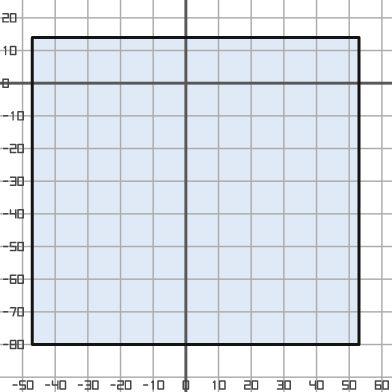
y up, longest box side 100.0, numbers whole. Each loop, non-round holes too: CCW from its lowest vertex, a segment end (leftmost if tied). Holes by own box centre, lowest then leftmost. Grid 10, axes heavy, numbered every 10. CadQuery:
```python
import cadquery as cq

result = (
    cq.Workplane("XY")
    .moveTo(-47.0, -80.0)
    .lineTo(53.0, -80.0)
    .lineTo(53.0, 14.0)
    .lineTo(-47.0, 14.0)
    .close()
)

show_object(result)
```